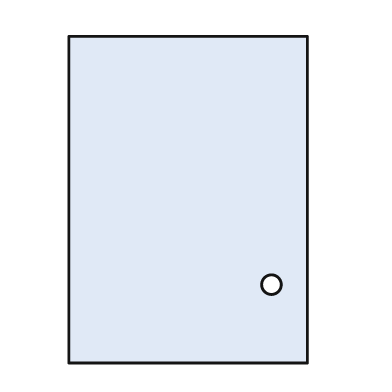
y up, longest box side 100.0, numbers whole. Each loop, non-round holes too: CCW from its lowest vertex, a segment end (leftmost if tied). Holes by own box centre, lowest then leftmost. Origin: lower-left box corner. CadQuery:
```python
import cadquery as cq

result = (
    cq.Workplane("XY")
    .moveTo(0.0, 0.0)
    .lineTo(73.0, 0.0)
    .lineTo(73.0, 100.0)
    .lineTo(0.0, 100.0)
    .close()
    .moveTo(62.0, 24.0)
    .circle(3.0)
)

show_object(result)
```